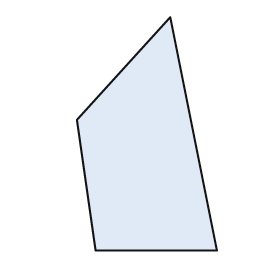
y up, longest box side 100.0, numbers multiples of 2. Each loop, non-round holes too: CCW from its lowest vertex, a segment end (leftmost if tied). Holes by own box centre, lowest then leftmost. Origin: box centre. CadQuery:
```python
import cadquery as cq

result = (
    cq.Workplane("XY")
    .moveTo(-22.0, -50.0)
    .lineTo(30.0, -50.0)
    .lineTo(10.0, 50.0)
    .lineTo(-30.0, 6.0)
    .close()
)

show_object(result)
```